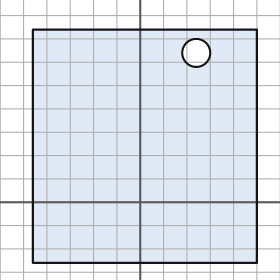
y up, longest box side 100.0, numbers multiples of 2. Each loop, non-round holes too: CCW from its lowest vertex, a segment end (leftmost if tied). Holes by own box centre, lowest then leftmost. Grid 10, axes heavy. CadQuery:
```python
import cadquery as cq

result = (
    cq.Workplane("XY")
    .moveTo(-46.0, -26.0)
    .lineTo(50.0, -26.0)
    .lineTo(50.0, 74.0)
    .lineTo(-46.0, 74.0)
    .close()
    .moveTo(24.0, 64.0)
    .circle(6.0)
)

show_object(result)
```